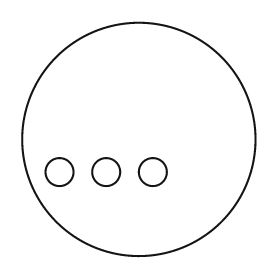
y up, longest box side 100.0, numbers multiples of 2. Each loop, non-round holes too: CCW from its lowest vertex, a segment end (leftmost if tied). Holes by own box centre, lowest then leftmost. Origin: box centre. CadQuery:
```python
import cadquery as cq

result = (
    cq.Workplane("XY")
    .moveTo(0.0, 0.0)
    .circle(50.0)
    .moveTo(-34.0, -14.0)
    .circle(6.0)
    .moveTo(-14.0, -14.0)
    .circle(6.0)
    .moveTo(6.0, -14.0)
    .circle(6.0)
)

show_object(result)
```